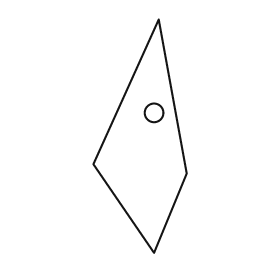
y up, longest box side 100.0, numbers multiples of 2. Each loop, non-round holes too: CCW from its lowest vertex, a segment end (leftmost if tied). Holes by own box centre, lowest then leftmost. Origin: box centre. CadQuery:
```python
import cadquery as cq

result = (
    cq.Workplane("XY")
    .moveTo(6.0, -50.0)
    .lineTo(20.0, -16.0)
    .lineTo(8.0, 50.0)
    .lineTo(-20.0, -12.0)
    .close()
    .moveTo(6.0, 10.0)
    .circle(4.0)
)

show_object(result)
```